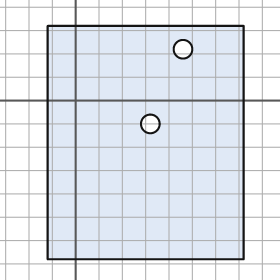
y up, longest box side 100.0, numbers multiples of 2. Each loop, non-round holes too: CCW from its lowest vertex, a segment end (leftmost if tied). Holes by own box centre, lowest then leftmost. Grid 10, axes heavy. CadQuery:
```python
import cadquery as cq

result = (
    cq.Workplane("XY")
    .moveTo(-12.0, -68.0)
    .lineTo(72.0, -68.0)
    .lineTo(72.0, 32.0)
    .lineTo(-12.0, 32.0)
    .close()
    .moveTo(32.0, -10.0)
    .circle(4.0)
    .moveTo(46.0, 22.0)
    .circle(4.0)
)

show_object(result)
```